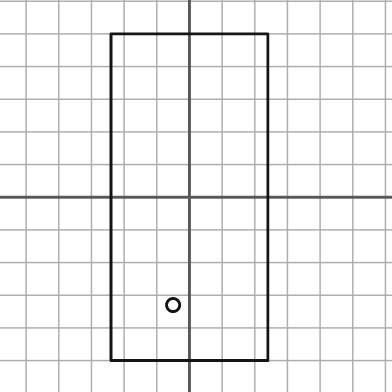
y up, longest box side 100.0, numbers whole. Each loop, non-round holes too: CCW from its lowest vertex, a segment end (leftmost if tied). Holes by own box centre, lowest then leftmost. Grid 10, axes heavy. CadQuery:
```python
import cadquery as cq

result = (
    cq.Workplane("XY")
    .moveTo(-24.0, -50.0)
    .lineTo(24.0, -50.0)
    .lineTo(24.0, 50.0)
    .lineTo(-24.0, 50.0)
    .close()
    .moveTo(-5.0, -33.0)
    .circle(2.0)
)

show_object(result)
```